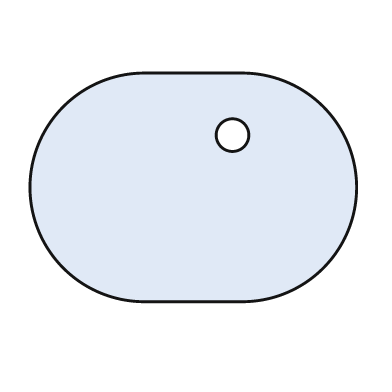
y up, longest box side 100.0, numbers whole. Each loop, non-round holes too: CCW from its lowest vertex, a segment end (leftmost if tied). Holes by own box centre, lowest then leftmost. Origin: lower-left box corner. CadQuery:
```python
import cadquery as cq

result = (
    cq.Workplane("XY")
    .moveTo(35.0, 0.0)
    .lineTo(65.0, 0.0)
    .threePointArc((100.0, 35.0), (65.0, 70.0))
    .lineTo(35.0, 70.0)
    .threePointArc((0.0, 35.0), (35.0, 0.0))
    .close()
    .moveTo(62.0, 51.0)
    .circle(5.0)
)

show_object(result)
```